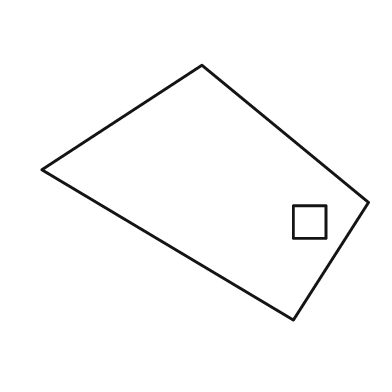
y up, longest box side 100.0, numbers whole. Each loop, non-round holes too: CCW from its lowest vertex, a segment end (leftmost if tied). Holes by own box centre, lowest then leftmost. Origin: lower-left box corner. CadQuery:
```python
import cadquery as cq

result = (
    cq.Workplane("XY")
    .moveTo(77.0, 0.0)
    .lineTo(100.0, 36.0)
    .lineTo(49.0, 78.0)
    .lineTo(0.0, 46.0)
    .close()
    .moveTo(77.0, 25.0)
    .lineTo(87.0, 25.0)
    .lineTo(87.0, 35.0)
    .lineTo(77.0, 35.0)
    .close()
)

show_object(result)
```